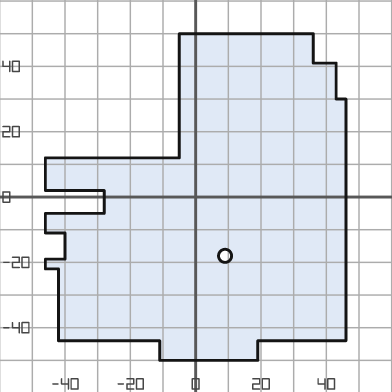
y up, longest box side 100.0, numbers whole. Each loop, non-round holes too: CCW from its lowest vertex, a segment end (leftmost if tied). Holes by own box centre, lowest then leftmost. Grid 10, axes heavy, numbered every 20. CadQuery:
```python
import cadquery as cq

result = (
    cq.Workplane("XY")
    .moveTo(-11.0, -50.0)
    .lineTo(19.0, -50.0)
    .lineTo(19.0, -44.0)
    .lineTo(46.0, -44.0)
    .lineTo(46.0, 30.0)
    .lineTo(43.0, 30.0)
    .lineTo(43.0, 41.0)
    .lineTo(36.0, 41.0)
    .lineTo(36.0, 50.0)
    .lineTo(-5.0, 50.0)
    .lineTo(-5.0, 12.0)
    .lineTo(-46.0, 12.0)
    .lineTo(-46.0, 2.0)
    .lineTo(-28.0, 2.0)
    .lineTo(-28.0, -5.0)
    .lineTo(-46.0, -5.0)
    .lineTo(-46.0, -11.0)
    .lineTo(-40.0, -11.0)
    .lineTo(-40.0, -19.0)
    .lineTo(-46.0, -19.0)
    .lineTo(-46.0, -22.0)
    .lineTo(-42.0, -22.0)
    .lineTo(-42.0, -44.0)
    .lineTo(-11.0, -44.0)
    .close()
    .moveTo(9.0, -18.0)
    .circle(2.0)
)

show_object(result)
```